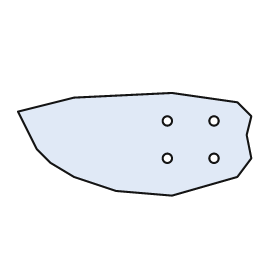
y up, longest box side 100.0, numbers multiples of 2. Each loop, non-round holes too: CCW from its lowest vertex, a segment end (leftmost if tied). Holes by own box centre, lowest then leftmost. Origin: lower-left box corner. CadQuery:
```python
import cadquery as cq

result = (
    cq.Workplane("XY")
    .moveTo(66.0, 0.0)
    .lineTo(94.0, 8.0)
    .lineTo(100.0, 16.0)
    .lineTo(98.0, 26.0)
    .lineTo(100.0, 34.0)
    .lineTo(94.0, 40.0)
    .lineTo(66.0, 44.0)
    .lineTo(24.0, 42.0)
    .lineTo(0.0, 36.0)
    .lineTo(8.0, 20.0)
    .lineTo(14.0, 14.0)
    .lineTo(24.0, 8.0)
    .lineTo(42.0, 2.0)
    .close()
    .moveTo(64.0, 16.0)
    .circle(2.0)
    .moveTo(84.0, 16.0)
    .circle(2.0)
    .moveTo(64.0, 32.0)
    .circle(2.0)
    .moveTo(84.0, 32.0)
    .circle(2.0)
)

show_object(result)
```